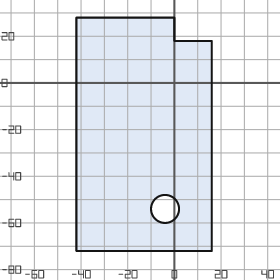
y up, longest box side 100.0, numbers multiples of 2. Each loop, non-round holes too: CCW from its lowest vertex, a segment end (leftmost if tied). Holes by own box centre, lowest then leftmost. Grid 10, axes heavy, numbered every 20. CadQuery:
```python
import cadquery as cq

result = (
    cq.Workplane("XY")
    .moveTo(-42.0, -72.0)
    .lineTo(16.0, -72.0)
    .lineTo(16.0, 18.0)
    .lineTo(0.0, 18.0)
    .lineTo(0.0, 28.0)
    .lineTo(-42.0, 28.0)
    .close()
    .moveTo(-4.0, -54.0)
    .circle(6.0)
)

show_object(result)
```